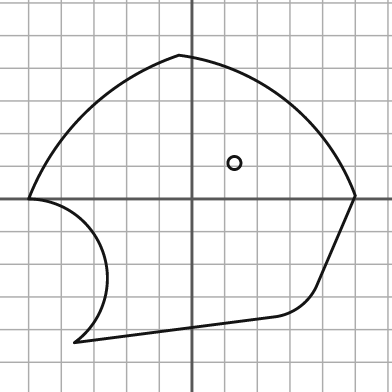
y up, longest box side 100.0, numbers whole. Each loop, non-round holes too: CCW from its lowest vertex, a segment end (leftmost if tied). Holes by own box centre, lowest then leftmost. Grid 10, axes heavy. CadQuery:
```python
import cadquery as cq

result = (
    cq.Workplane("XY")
    .moveTo(-36.0, -44.0)
    .lineTo(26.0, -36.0)
    .threePointArc((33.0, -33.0), (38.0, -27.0))
    .lineTo(50.0, 1.0)
    .threePointArc((29.0, 30.0), (-4.0, 44.0))
    .threePointArc((-32.0, 27.0), (-50.0, 0.0))
    .threePointArc((-27.0, -17.0), (-36.0, -44.0))
    .close()
    .moveTo(13.0, 11.0)
    .circle(2.0)
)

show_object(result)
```